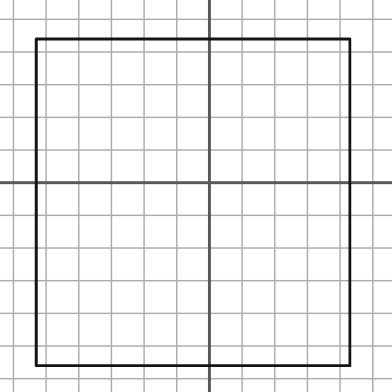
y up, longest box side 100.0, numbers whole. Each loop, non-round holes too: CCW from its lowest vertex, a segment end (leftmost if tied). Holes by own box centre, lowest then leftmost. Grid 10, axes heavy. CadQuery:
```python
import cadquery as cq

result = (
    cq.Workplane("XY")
    .moveTo(-53.0, -56.0)
    .lineTo(43.0, -56.0)
    .lineTo(43.0, 44.0)
    .lineTo(-53.0, 44.0)
    .close()
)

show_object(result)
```